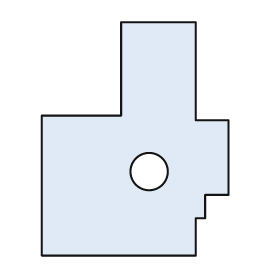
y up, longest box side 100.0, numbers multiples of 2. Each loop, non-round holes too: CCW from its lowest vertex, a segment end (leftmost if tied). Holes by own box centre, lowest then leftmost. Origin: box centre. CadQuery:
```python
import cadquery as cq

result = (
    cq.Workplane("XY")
    .moveTo(-40.0, -50.0)
    .lineTo(26.0, -50.0)
    .lineTo(26.0, -34.0)
    .lineTo(30.0, -34.0)
    .lineTo(30.0, -24.0)
    .lineTo(40.0, -24.0)
    .lineTo(40.0, 8.0)
    .lineTo(26.0, 8.0)
    .lineTo(26.0, 50.0)
    .lineTo(-6.0, 50.0)
    .lineTo(-6.0, 10.0)
    .lineTo(-40.0, 10.0)
    .close()
    .moveTo(6.0, -14.0)
    .circle(8.0)
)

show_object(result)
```